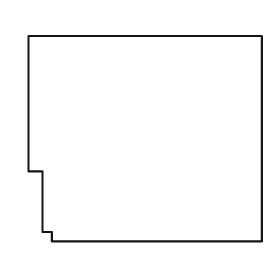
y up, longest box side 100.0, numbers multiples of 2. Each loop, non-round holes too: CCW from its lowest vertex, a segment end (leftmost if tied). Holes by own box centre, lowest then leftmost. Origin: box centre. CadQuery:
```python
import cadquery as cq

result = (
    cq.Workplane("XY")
    .moveTo(-40.0, -44.0)
    .lineTo(50.0, -44.0)
    .lineTo(50.0, 44.0)
    .lineTo(-50.0, 44.0)
    .lineTo(-50.0, -14.0)
    .lineTo(-44.0, -14.0)
    .lineTo(-44.0, -40.0)
    .lineTo(-40.0, -40.0)
    .close()
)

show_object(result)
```